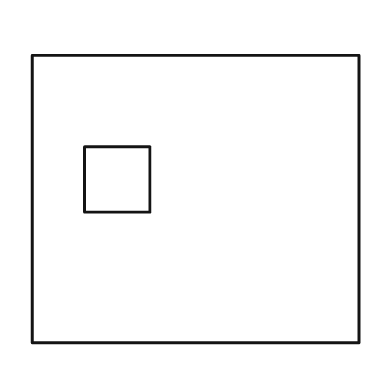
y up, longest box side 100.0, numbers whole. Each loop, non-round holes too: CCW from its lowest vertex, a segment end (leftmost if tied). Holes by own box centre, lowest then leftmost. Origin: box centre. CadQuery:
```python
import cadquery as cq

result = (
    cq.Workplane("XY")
    .moveTo(-50.0, -44.0)
    .lineTo(50.0, -44.0)
    .lineTo(50.0, 44.0)
    .lineTo(-50.0, 44.0)
    .close()
    .moveTo(-34.0, -4.0)
    .lineTo(-14.0, -4.0)
    .lineTo(-14.0, 16.0)
    .lineTo(-34.0, 16.0)
    .close()
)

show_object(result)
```